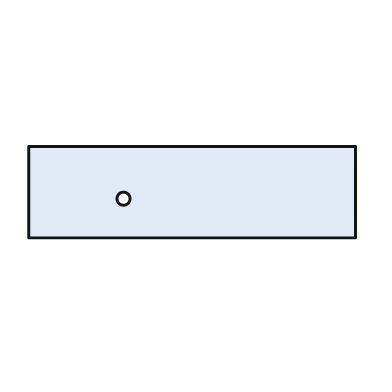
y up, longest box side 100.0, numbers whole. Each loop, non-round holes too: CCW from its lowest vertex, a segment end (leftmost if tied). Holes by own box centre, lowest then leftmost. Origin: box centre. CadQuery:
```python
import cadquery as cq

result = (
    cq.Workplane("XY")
    .moveTo(-50.0, -14.0)
    .lineTo(50.0, -14.0)
    .lineTo(50.0, 14.0)
    .lineTo(-50.0, 14.0)
    .close()
    .moveTo(-21.0, -2.0)
    .circle(2.0)
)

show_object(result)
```